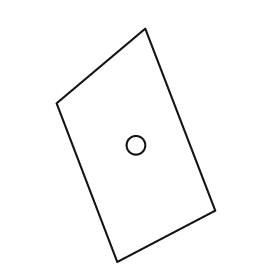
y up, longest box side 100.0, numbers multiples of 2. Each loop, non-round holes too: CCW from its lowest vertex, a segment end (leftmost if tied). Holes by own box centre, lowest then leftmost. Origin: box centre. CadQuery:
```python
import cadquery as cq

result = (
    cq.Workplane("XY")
    .moveTo(-8.0, -50.0)
    .lineTo(34.0, -28.0)
    .lineTo(4.0, 50.0)
    .lineTo(-34.0, 18.0)
    .close()
    .moveTo(0.0, 0.0)
    .circle(4.0)
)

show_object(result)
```